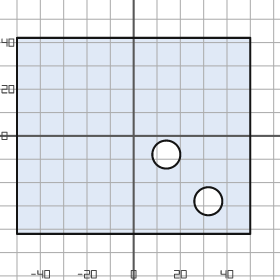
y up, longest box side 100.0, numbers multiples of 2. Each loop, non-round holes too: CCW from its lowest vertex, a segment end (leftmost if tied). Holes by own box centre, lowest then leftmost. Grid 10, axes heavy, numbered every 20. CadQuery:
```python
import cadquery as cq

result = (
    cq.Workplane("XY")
    .moveTo(-50.0, -42.0)
    .lineTo(50.0, -42.0)
    .lineTo(50.0, 42.0)
    .lineTo(-50.0, 42.0)
    .close()
    .moveTo(32.0, -28.0)
    .circle(6.0)
    .moveTo(14.0, -8.0)
    .circle(6.0)
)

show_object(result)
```